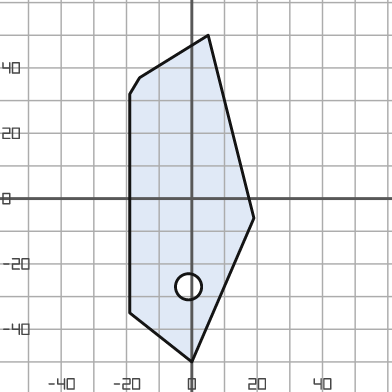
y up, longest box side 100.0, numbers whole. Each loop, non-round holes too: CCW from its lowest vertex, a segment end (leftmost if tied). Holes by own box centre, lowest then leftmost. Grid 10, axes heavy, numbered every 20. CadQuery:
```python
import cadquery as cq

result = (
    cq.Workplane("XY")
    .moveTo(0.0, -50.0)
    .lineTo(19.0, -6.0)
    .lineTo(5.0, 50.0)
    .lineTo(-16.0, 37.0)
    .lineTo(-19.0, 32.0)
    .lineTo(-19.0, -35.0)
    .close()
    .moveTo(-1.0, -27.0)
    .circle(4.0)
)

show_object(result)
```